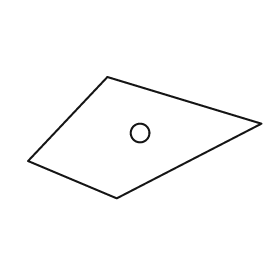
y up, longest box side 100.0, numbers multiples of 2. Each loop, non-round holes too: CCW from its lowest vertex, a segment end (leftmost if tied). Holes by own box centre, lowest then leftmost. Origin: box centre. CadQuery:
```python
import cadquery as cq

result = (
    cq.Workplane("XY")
    .moveTo(-12.0, -26.0)
    .lineTo(50.0, 6.0)
    .lineTo(-16.0, 26.0)
    .lineTo(-50.0, -10.0)
    .close()
    .moveTo(-2.0, 2.0)
    .circle(4.0)
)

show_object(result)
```